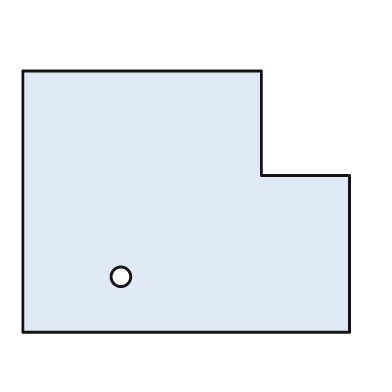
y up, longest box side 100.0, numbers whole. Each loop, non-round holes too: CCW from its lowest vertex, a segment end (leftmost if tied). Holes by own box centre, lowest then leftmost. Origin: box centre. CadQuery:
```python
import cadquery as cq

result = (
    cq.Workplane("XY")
    .moveTo(-50.0, -40.0)
    .lineTo(50.0, -40.0)
    .lineTo(50.0, 8.0)
    .lineTo(23.0, 8.0)
    .lineTo(23.0, 40.0)
    .lineTo(-50.0, 40.0)
    .close()
    .moveTo(-20.0, -23.0)
    .circle(3.0)
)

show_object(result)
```